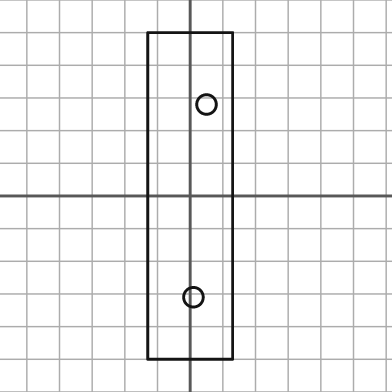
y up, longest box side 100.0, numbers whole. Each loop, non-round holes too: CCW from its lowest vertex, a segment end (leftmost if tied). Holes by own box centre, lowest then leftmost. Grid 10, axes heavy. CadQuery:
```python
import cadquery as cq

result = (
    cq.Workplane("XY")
    .moveTo(-13.0, -50.0)
    .lineTo(13.0, -50.0)
    .lineTo(13.0, 50.0)
    .lineTo(-13.0, 50.0)
    .close()
    .moveTo(1.0, -31.0)
    .circle(3.0)
    .moveTo(5.0, 28.0)
    .circle(3.0)
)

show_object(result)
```